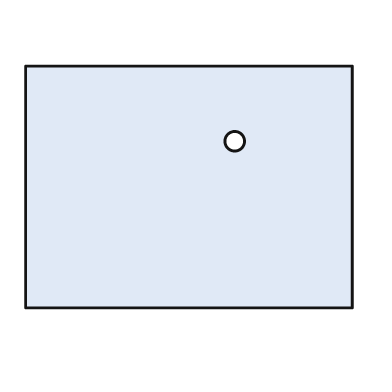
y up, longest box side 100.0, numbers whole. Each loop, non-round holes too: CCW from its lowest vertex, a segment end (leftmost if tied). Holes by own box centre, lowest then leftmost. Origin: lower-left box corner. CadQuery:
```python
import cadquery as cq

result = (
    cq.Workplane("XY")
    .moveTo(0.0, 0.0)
    .lineTo(100.0, 0.0)
    .lineTo(100.0, 74.0)
    .lineTo(0.0, 74.0)
    .close()
    .moveTo(64.0, 51.0)
    .circle(3.0)
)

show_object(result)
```